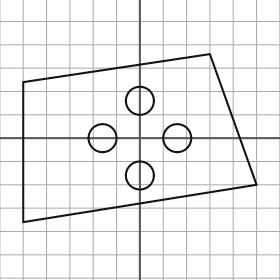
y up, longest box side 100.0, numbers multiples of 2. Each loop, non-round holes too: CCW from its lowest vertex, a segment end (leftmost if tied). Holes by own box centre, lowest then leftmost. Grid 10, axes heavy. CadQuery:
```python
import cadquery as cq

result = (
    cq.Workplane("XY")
    .moveTo(-50.0, -36.0)
    .lineTo(50.0, -20.0)
    .lineTo(30.0, 36.0)
    .lineTo(-50.0, 24.0)
    .close()
    .moveTo(0.0, -16.0)
    .circle(6.0)
    .moveTo(-16.0, 0.0)
    .circle(6.0)
    .moveTo(16.0, 0.0)
    .circle(6.0)
    .moveTo(0.0, 16.0)
    .circle(6.0)
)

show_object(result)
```